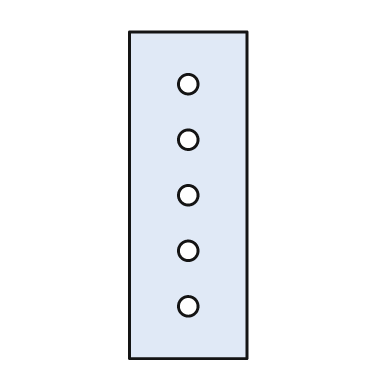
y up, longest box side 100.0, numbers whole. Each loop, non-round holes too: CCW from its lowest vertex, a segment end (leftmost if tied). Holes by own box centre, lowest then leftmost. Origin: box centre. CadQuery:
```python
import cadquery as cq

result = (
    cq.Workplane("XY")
    .moveTo(-18.0, -50.0)
    .lineTo(18.0, -50.0)
    .lineTo(18.0, 50.0)
    .lineTo(-18.0, 50.0)
    .close()
    .moveTo(0.0, -34.0)
    .circle(3.0)
    .moveTo(0.0, -17.0)
    .circle(3.0)
    .moveTo(0.0, 0.0)
    .circle(3.0)
    .moveTo(0.0, 17.0)
    .circle(3.0)
    .moveTo(0.0, 34.0)
    .circle(3.0)
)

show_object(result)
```